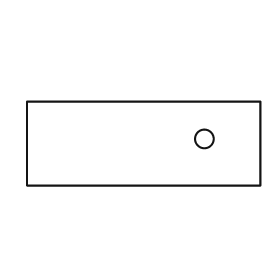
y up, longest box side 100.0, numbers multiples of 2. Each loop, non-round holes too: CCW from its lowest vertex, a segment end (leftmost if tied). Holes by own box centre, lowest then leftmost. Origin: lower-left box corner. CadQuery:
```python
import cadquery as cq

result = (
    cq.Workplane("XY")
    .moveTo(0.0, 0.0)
    .lineTo(100.0, 0.0)
    .lineTo(100.0, 36.0)
    .lineTo(0.0, 36.0)
    .close()
    .moveTo(76.0, 20.0)
    .circle(4.0)
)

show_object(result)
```